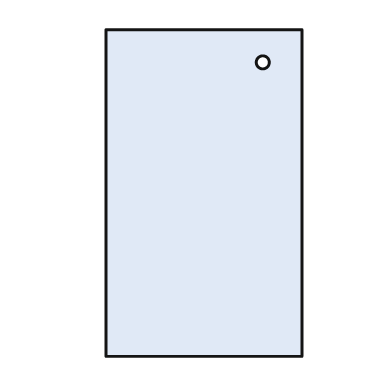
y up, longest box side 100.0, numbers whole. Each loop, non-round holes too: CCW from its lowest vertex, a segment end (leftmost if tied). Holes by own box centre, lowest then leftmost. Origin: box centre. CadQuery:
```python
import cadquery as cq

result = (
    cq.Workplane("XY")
    .moveTo(-30.0, -50.0)
    .lineTo(30.0, -50.0)
    .lineTo(30.0, 50.0)
    .lineTo(-30.0, 50.0)
    .close()
    .moveTo(18.0, 40.0)
    .circle(2.0)
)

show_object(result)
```